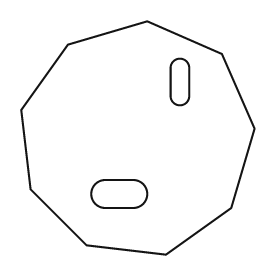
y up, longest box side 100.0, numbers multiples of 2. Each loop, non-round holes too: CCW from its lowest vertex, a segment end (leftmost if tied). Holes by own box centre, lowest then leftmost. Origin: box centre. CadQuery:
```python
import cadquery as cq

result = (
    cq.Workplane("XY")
    .moveTo(12.0, -50.0)
    .lineTo(40.0, -30.0)
    .lineTo(50.0, 4.0)
    .lineTo(36.0, 36.0)
    .lineTo(4.0, 50.0)
    .lineTo(-30.0, 40.0)
    .lineTo(-50.0, 12.0)
    .lineTo(-46.0, -22.0)
    .lineTo(-22.0, -46.0)
    .close()
    .moveTo(-14.0, -30.0)
    .lineTo(-2.0, -30.0)
    .threePointArc((4.0, -24.0), (-2.0, -18.0))
    .lineTo(-14.0, -18.0)
    .threePointArc((-20.0, -24.0), (-14.0, -30.0))
    .close()
    .moveTo(14.0, 18.0)
    .threePointArc((18.0, 14.0), (22.0, 18.0))
    .lineTo(22.0, 30.0)
    .threePointArc((18.0, 34.0), (14.0, 30.0))
    .close()
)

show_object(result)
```